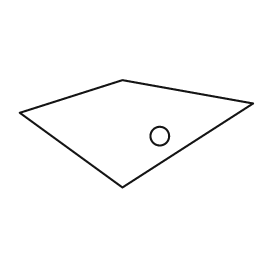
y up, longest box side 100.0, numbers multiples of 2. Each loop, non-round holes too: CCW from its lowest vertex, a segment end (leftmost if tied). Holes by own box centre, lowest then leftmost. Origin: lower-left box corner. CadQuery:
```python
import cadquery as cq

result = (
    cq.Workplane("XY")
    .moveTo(44.0, 0.0)
    .lineTo(100.0, 36.0)
    .lineTo(44.0, 46.0)
    .lineTo(0.0, 32.0)
    .close()
    .moveTo(60.0, 22.0)
    .circle(4.0)
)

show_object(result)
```